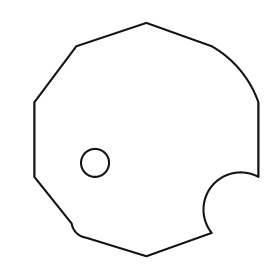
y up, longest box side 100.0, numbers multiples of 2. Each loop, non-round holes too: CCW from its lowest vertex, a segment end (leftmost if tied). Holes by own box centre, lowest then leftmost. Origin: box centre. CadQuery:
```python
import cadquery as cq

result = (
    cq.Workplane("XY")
    .moveTo(0.0, -50.0)
    .lineTo(28.0, -40.0)
    .threePointArc((28.0, -20.0), (48.0, -16.0))
    .lineTo(48.0, 16.0)
    .threePointArc((40.0, 30.0), (28.0, 40.0))
    .lineTo(0.0, 50.0)
    .lineTo(-30.0, 40.0)
    .lineTo(-48.0, 16.0)
    .lineTo(-48.0, -16.0)
    .lineTo(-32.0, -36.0)
    .threePointArc((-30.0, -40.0), (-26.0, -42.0))
    .close()
    .moveTo(-22.0, -10.0)
    .circle(6.0)
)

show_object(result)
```